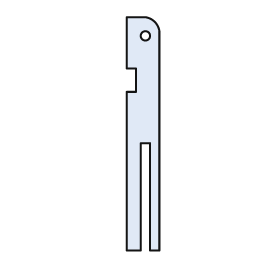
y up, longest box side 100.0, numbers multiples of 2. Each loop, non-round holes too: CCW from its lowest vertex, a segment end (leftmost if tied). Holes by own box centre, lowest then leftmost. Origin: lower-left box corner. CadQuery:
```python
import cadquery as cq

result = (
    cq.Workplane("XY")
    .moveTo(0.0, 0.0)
    .lineTo(6.0, 0.0)
    .lineTo(6.0, 46.0)
    .lineTo(10.0, 46.0)
    .lineTo(10.0, 0.0)
    .lineTo(14.0, 0.0)
    .lineTo(14.0, 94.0)
    .threePointArc((12.0, 98.0), (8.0, 100.0))
    .lineTo(0.0, 100.0)
    .lineTo(0.0, 78.0)
    .lineTo(4.0, 78.0)
    .lineTo(4.0, 68.0)
    .lineTo(0.0, 68.0)
    .close()
    .moveTo(8.0, 92.0)
    .circle(2.0)
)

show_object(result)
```